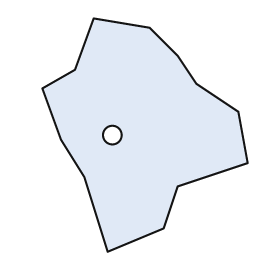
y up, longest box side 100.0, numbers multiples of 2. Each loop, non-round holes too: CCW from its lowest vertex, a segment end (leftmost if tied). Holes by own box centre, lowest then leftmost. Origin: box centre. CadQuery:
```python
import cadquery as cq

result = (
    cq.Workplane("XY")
    .moveTo(-16.0, -50.0)
    .lineTo(8.0, -40.0)
    .lineTo(14.0, -22.0)
    .lineTo(44.0, -12.0)
    .lineTo(40.0, 10.0)
    .lineTo(22.0, 22.0)
    .lineTo(14.0, 34.0)
    .lineTo(2.0, 46.0)
    .lineTo(-22.0, 50.0)
    .lineTo(-30.0, 28.0)
    .lineTo(-44.0, 20.0)
    .lineTo(-36.0, -2.0)
    .lineTo(-26.0, -18.0)
    .close()
    .moveTo(-14.0, 0.0)
    .circle(4.0)
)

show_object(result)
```